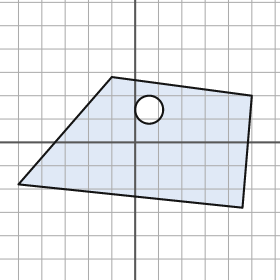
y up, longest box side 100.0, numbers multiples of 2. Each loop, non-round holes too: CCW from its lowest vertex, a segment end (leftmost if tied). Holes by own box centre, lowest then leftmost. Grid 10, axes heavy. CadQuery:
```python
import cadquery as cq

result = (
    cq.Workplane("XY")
    .moveTo(46.0, -28.0)
    .lineTo(50.0, 20.0)
    .lineTo(-10.0, 28.0)
    .lineTo(-50.0, -18.0)
    .close()
    .moveTo(6.0, 14.0)
    .circle(6.0)
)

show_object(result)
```